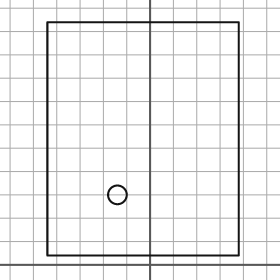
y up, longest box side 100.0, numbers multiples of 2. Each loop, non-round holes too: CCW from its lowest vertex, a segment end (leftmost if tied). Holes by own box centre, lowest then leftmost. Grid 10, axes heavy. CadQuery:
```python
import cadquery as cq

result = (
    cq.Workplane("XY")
    .moveTo(-44.0, 4.0)
    .lineTo(38.0, 4.0)
    .lineTo(38.0, 104.0)
    .lineTo(-44.0, 104.0)
    .close()
    .moveTo(-14.0, 30.0)
    .circle(4.0)
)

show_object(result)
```